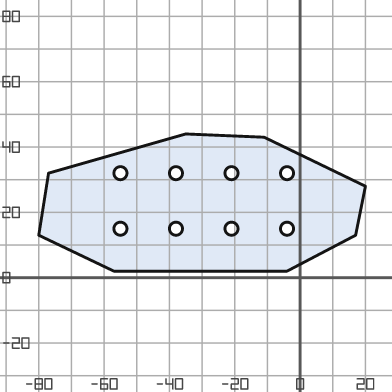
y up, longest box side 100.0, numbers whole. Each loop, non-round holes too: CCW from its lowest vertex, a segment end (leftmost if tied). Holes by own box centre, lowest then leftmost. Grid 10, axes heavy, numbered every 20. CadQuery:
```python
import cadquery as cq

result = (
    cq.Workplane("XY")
    .moveTo(-57.0, 2.0)
    .lineTo(-4.0, 2.0)
    .lineTo(17.0, 13.0)
    .lineTo(20.0, 28.0)
    .lineTo(-11.0, 43.0)
    .lineTo(-35.0, 44.0)
    .lineTo(-77.0, 32.0)
    .lineTo(-80.0, 13.0)
    .close()
    .moveTo(-55.0, 15.0)
    .circle(2.0)
    .moveTo(-38.0, 15.0)
    .circle(2.0)
    .moveTo(-21.0, 15.0)
    .circle(2.0)
    .moveTo(-4.0, 15.0)
    .circle(2.0)
    .moveTo(-55.0, 32.0)
    .circle(2.0)
    .moveTo(-38.0, 32.0)
    .circle(2.0)
    .moveTo(-21.0, 32.0)
    .circle(2.0)
    .moveTo(-4.0, 32.0)
    .circle(2.0)
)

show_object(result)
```